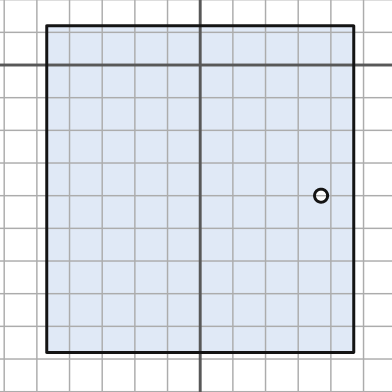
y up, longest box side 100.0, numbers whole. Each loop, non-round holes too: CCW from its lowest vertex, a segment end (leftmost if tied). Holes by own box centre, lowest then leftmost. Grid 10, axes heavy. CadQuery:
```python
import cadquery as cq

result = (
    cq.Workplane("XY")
    .moveTo(-47.0, -88.0)
    .lineTo(47.0, -88.0)
    .lineTo(47.0, 12.0)
    .lineTo(-47.0, 12.0)
    .close()
    .moveTo(37.0, -40.0)
    .circle(2.0)
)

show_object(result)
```